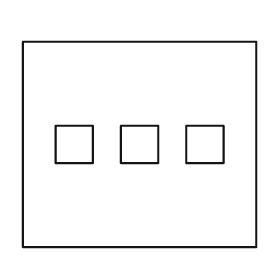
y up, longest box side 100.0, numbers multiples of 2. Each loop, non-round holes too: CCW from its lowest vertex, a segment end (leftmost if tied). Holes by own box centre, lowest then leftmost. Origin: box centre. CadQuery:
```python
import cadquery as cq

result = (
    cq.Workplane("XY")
    .moveTo(-50.0, -44.0)
    .lineTo(50.0, -44.0)
    .lineTo(50.0, 44.0)
    .lineTo(-50.0, 44.0)
    .close()
    .moveTo(-36.0, -8.0)
    .lineTo(-20.0, -8.0)
    .lineTo(-20.0, 8.0)
    .lineTo(-36.0, 8.0)
    .close()
    .moveTo(-8.0, -8.0)
    .lineTo(8.0, -8.0)
    .lineTo(8.0, 8.0)
    .lineTo(-8.0, 8.0)
    .close()
    .moveTo(20.0, -8.0)
    .lineTo(36.0, -8.0)
    .lineTo(36.0, 8.0)
    .lineTo(20.0, 8.0)
    .close()
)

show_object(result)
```